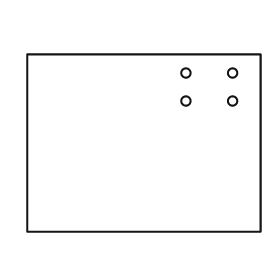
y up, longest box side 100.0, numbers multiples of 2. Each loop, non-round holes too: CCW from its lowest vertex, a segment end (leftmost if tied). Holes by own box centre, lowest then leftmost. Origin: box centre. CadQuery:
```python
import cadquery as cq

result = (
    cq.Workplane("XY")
    .moveTo(-50.0, -38.0)
    .lineTo(50.0, -38.0)
    .lineTo(50.0, 38.0)
    .lineTo(-50.0, 38.0)
    .close()
    .moveTo(18.0, 18.0)
    .circle(2.0)
    .moveTo(38.0, 18.0)
    .circle(2.0)
    .moveTo(18.0, 30.0)
    .circle(2.0)
    .moveTo(38.0, 30.0)
    .circle(2.0)
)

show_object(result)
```